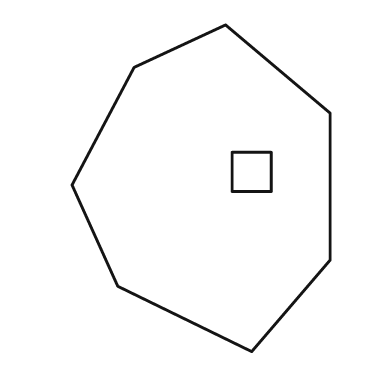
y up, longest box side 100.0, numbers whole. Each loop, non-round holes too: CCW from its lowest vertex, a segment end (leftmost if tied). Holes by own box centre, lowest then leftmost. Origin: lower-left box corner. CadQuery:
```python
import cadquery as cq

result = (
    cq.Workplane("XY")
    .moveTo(55.0, 0.0)
    .lineTo(79.0, 28.0)
    .lineTo(79.0, 73.0)
    .lineTo(47.0, 100.0)
    .lineTo(19.0, 87.0)
    .lineTo(0.0, 51.0)
    .lineTo(14.0, 20.0)
    .close()
    .moveTo(49.0, 49.0)
    .lineTo(61.0, 49.0)
    .lineTo(61.0, 61.0)
    .lineTo(49.0, 61.0)
    .close()
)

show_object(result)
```